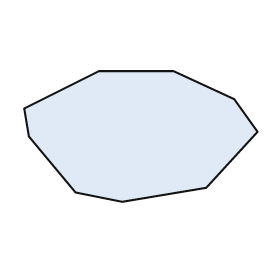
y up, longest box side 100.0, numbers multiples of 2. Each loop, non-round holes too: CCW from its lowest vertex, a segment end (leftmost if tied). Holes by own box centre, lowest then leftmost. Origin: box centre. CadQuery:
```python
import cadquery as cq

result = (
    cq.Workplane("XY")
    .moveTo(-8.0, -28.0)
    .lineTo(28.0, -22.0)
    .lineTo(50.0, 2.0)
    .lineTo(40.0, 16.0)
    .lineTo(14.0, 28.0)
    .lineTo(-18.0, 28.0)
    .lineTo(-50.0, 12.0)
    .lineTo(-48.0, 0.0)
    .lineTo(-28.0, -24.0)
    .close()
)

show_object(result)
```